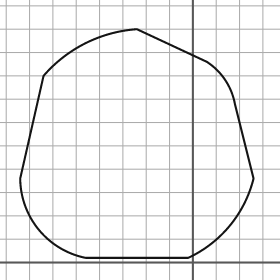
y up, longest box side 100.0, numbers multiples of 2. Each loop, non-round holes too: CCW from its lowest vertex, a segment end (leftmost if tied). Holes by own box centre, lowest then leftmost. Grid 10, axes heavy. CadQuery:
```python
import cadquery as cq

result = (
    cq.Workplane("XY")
    .moveTo(-46.0, 2.0)
    .lineTo(-2.0, 2.0)
    .threePointArc((16.0, 16.0), (26.0, 36.0))
    .lineTo(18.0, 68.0)
    .threePointArc((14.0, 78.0), (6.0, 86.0))
    .lineTo(-24.0, 100.0)
    .threePointArc((-46.0, 94.0), (-64.0, 80.0))
    .lineTo(-74.0, 36.0)
    .threePointArc((-66.0, 14.0), (-46.0, 2.0))
    .close()
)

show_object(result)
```